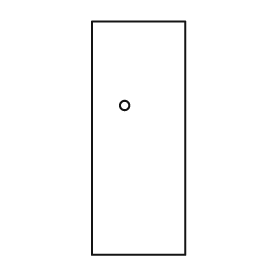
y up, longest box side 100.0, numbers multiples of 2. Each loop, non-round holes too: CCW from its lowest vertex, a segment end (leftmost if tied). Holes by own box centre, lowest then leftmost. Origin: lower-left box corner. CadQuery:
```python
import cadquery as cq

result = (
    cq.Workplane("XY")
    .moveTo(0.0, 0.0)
    .lineTo(40.0, 0.0)
    .lineTo(40.0, 100.0)
    .lineTo(0.0, 100.0)
    .close()
    .moveTo(14.0, 64.0)
    .circle(2.0)
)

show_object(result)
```